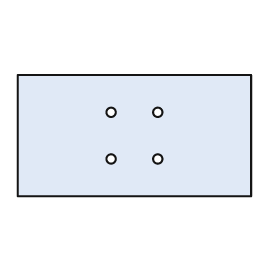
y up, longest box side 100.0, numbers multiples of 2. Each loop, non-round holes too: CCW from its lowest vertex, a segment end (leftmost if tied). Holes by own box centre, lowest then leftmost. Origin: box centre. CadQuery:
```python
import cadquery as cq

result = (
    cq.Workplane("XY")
    .moveTo(-50.0, -26.0)
    .lineTo(50.0, -26.0)
    .lineTo(50.0, 26.0)
    .lineTo(-50.0, 26.0)
    .close()
    .moveTo(-10.0, -10.0)
    .circle(2.0)
    .moveTo(10.0, -10.0)
    .circle(2.0)
    .moveTo(-10.0, 10.0)
    .circle(2.0)
    .moveTo(10.0, 10.0)
    .circle(2.0)
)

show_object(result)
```